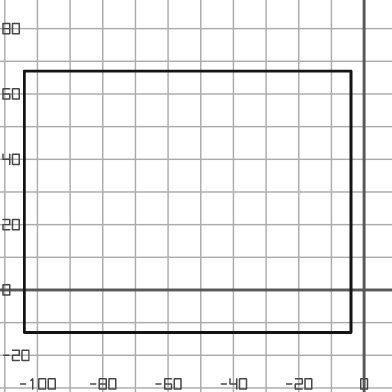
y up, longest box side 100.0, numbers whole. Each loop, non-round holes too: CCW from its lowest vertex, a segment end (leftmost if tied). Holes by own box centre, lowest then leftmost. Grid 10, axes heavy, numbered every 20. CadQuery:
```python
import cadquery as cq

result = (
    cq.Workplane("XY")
    .moveTo(-104.0, -13.0)
    .lineTo(-4.0, -13.0)
    .lineTo(-4.0, 67.0)
    .lineTo(-104.0, 67.0)
    .close()
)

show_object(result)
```